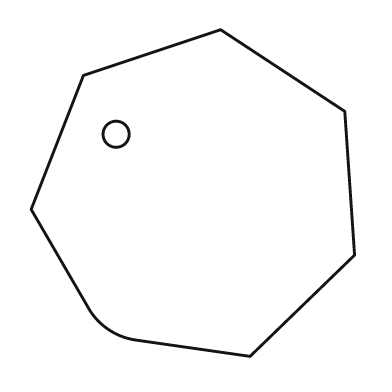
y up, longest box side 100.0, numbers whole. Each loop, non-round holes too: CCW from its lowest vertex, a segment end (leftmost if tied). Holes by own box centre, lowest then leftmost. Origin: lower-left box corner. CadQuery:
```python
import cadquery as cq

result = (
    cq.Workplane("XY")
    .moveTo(67.0, 0.0)
    .lineTo(99.0, 31.0)
    .lineTo(96.0, 75.0)
    .lineTo(58.0, 100.0)
    .lineTo(16.0, 86.0)
    .lineTo(0.0, 45.0)
    .lineTo(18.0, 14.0)
    .threePointArc((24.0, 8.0), (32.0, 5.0))
    .close()
    .moveTo(26.0, 68.0)
    .circle(4.0)
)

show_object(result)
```